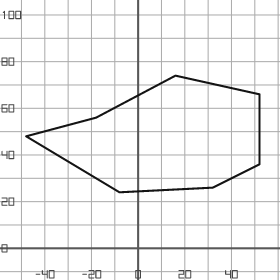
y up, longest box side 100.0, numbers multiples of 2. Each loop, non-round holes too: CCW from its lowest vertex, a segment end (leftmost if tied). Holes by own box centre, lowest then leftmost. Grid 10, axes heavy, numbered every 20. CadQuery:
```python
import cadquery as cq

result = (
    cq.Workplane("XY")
    .moveTo(-8.0, 24.0)
    .lineTo(32.0, 26.0)
    .lineTo(52.0, 36.0)
    .lineTo(52.0, 66.0)
    .lineTo(16.0, 74.0)
    .lineTo(-18.0, 56.0)
    .lineTo(-48.0, 48.0)
    .close()
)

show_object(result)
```